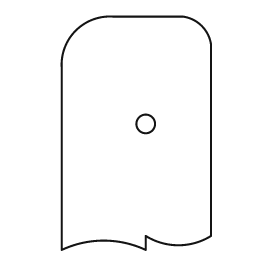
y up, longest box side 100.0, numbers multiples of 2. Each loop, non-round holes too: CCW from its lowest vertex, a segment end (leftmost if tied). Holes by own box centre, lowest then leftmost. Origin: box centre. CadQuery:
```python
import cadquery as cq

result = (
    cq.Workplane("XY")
    .moveTo(-32.0, -50.0)
    .threePointArc((-14.0, -46.0), (4.0, -50.0))
    .lineTo(4.0, -44.0)
    .threePointArc((18.0, -48.0), (32.0, -44.0))
    .lineTo(32.0, 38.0)
    .threePointArc((28.0, 46.0), (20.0, 50.0))
    .lineTo(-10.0, 50.0)
    .threePointArc((-26.0, 44.0), (-32.0, 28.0))
    .close()
    .moveTo(4.0, 4.0)
    .circle(4.0)
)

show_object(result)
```